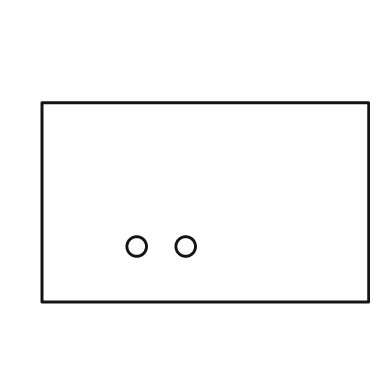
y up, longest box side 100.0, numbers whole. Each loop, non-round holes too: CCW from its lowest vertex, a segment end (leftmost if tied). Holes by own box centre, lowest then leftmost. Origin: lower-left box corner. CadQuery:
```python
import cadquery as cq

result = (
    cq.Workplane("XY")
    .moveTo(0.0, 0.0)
    .lineTo(100.0, 0.0)
    .lineTo(100.0, 61.0)
    .lineTo(0.0, 61.0)
    .close()
    .moveTo(29.0, 17.0)
    .circle(3.0)
    .moveTo(44.0, 17.0)
    .circle(3.0)
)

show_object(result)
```